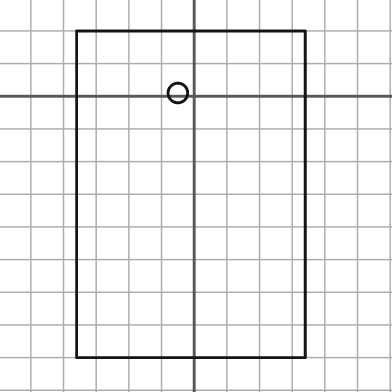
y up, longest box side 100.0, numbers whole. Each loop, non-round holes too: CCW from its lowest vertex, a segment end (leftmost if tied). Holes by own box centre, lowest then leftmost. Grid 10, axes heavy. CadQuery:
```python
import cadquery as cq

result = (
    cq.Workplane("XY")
    .moveTo(-36.0, -80.0)
    .lineTo(34.0, -80.0)
    .lineTo(34.0, 20.0)
    .lineTo(-36.0, 20.0)
    .close()
    .moveTo(-5.0, 1.0)
    .circle(3.0)
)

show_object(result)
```